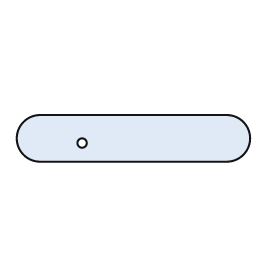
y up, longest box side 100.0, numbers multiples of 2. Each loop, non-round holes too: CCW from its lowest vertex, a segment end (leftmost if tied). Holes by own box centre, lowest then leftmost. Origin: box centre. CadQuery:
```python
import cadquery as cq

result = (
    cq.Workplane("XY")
    .moveTo(-40.0, -10.0)
    .lineTo(40.0, -10.0)
    .threePointArc((50.0, 0.0), (40.0, 10.0))
    .lineTo(-40.0, 10.0)
    .threePointArc((-50.0, 0.0), (-40.0, -10.0))
    .close()
    .moveTo(-22.0, -2.0)
    .circle(2.0)
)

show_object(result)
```